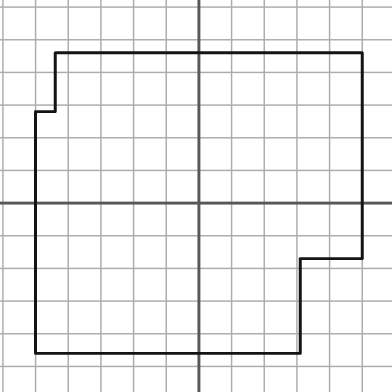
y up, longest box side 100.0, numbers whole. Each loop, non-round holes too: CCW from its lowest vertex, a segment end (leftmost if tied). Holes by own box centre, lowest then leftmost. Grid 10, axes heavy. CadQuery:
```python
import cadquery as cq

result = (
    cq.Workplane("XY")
    .moveTo(-50.0, -46.0)
    .lineTo(31.0, -46.0)
    .lineTo(31.0, -17.0)
    .lineTo(50.0, -17.0)
    .lineTo(50.0, 46.0)
    .lineTo(-44.0, 46.0)
    .lineTo(-44.0, 28.0)
    .lineTo(-50.0, 28.0)
    .close()
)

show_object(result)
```